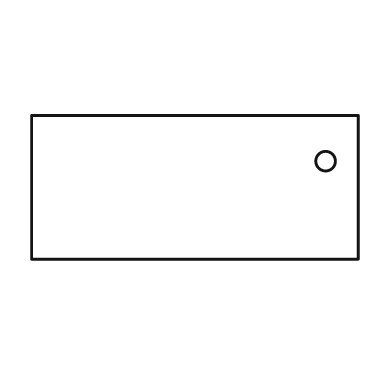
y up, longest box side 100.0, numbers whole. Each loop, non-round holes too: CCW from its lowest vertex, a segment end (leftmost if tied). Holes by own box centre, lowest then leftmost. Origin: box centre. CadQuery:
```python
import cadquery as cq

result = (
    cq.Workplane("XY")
    .moveTo(-50.0, -22.0)
    .lineTo(50.0, -22.0)
    .lineTo(50.0, 22.0)
    .lineTo(-50.0, 22.0)
    .close()
    .moveTo(40.0, 8.0)
    .circle(3.0)
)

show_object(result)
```